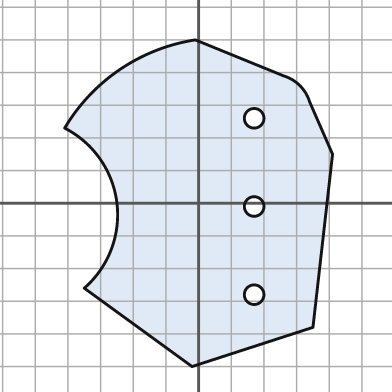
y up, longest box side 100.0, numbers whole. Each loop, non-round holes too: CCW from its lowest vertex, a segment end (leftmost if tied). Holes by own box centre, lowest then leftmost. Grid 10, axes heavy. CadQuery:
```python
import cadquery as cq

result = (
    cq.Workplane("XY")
    .moveTo(-2.0, -50.0)
    .lineTo(35.0, -38.0)
    .lineTo(41.0, 15.0)
    .lineTo(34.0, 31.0)
    .threePointArc((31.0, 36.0), (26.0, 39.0))
    .lineTo(-1.0, 50.0)
    .threePointArc((-24.0, 41.0), (-41.0, 23.0))
    .threePointArc((-25.0, 0.0), (-35.0, -26.0))
    .close()
    .moveTo(17.0, -28.0)
    .circle(3.0)
    .moveTo(17.0, -1.0)
    .circle(3.0)
    .moveTo(17.0, 26.0)
    .circle(3.0)
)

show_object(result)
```